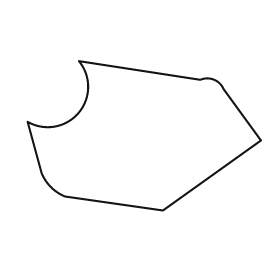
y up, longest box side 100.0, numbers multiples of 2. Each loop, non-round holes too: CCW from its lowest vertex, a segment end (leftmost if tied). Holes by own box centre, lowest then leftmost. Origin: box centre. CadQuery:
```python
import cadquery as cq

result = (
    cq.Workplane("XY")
    .moveTo(8.0, -32.0)
    .lineTo(50.0, -2.0)
    .lineTo(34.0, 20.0)
    .threePointArc((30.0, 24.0), (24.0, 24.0))
    .lineTo(-28.0, 32.0)
    .threePointArc((-28.0, 10.0), (-50.0, 6.0))
    .lineTo(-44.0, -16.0)
    .threePointArc((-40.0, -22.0), (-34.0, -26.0))
    .close()
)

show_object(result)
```